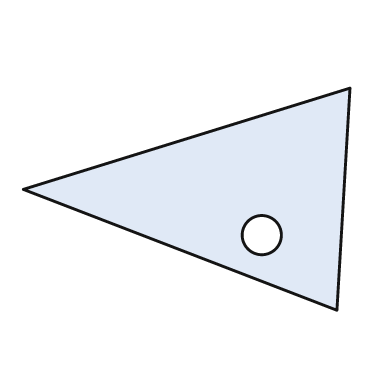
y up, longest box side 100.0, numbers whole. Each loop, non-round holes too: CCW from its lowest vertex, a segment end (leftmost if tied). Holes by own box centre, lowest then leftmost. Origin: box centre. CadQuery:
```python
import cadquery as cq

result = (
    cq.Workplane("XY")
    .moveTo(46.0, -34.0)
    .lineTo(50.0, 34.0)
    .lineTo(-50.0, 3.0)
    .close()
    .moveTo(23.0, -11.0)
    .circle(6.0)
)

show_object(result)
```